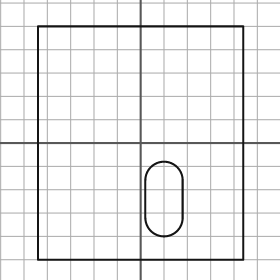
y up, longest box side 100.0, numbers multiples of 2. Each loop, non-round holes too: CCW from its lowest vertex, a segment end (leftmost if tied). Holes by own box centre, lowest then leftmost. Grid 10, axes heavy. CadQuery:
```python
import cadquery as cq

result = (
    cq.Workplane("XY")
    .moveTo(-44.0, -50.0)
    .lineTo(44.0, -50.0)
    .lineTo(44.0, 50.0)
    .lineTo(-44.0, 50.0)
    .close()
    .moveTo(2.0, -32.0)
    .threePointArc((10.0, -40.0), (18.0, -32.0))
    .lineTo(18.0, -16.0)
    .threePointArc((10.0, -8.0), (2.0, -16.0))
    .close()
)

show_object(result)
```